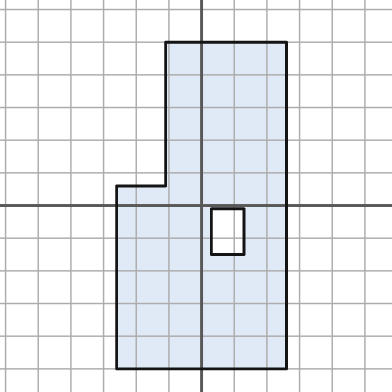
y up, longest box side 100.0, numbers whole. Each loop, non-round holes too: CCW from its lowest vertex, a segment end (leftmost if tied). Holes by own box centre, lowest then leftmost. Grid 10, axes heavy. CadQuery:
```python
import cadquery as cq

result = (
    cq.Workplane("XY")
    .moveTo(-26.0, -50.0)
    .lineTo(26.0, -50.0)
    .lineTo(26.0, 50.0)
    .lineTo(-11.0, 50.0)
    .lineTo(-11.0, 6.0)
    .lineTo(-26.0, 6.0)
    .close()
    .moveTo(3.0, -15.0)
    .lineTo(13.0, -15.0)
    .lineTo(13.0, -1.0)
    .lineTo(3.0, -1.0)
    .close()
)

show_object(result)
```